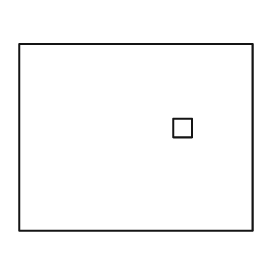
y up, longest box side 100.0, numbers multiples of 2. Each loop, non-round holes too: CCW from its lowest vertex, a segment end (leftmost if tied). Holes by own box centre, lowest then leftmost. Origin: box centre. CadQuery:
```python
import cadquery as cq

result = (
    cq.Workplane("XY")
    .moveTo(-50.0, -40.0)
    .lineTo(50.0, -40.0)
    .lineTo(50.0, 40.0)
    .lineTo(-50.0, 40.0)
    .close()
    .moveTo(16.0, 0.0)
    .lineTo(24.0, 0.0)
    .lineTo(24.0, 8.0)
    .lineTo(16.0, 8.0)
    .close()
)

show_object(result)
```